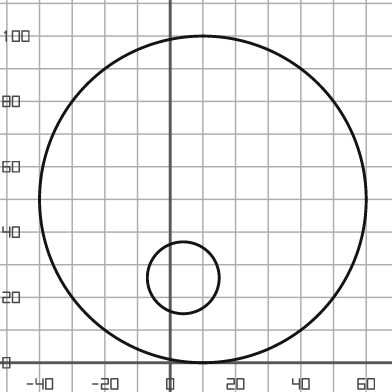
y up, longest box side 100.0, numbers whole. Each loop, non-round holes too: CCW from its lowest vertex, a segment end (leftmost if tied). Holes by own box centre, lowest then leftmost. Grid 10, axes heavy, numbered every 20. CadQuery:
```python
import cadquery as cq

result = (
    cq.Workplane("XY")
    .moveTo(10.0, 50.0)
    .circle(50.0)
    .moveTo(4.0, 26.0)
    .circle(11.0)
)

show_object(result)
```